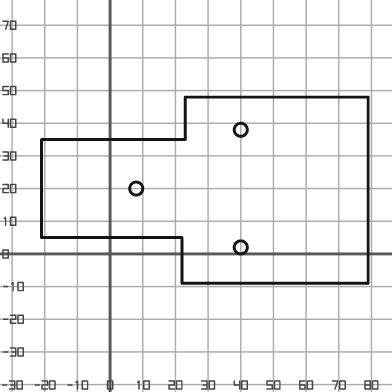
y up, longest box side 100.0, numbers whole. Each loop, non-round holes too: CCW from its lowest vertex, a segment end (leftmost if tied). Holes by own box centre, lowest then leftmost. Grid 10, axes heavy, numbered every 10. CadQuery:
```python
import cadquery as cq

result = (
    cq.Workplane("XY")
    .moveTo(22.0, -9.0)
    .lineTo(79.0, -9.0)
    .lineTo(79.0, 48.0)
    .lineTo(23.0, 48.0)
    .lineTo(23.0, 35.0)
    .lineTo(-21.0, 35.0)
    .lineTo(-21.0, 5.0)
    .lineTo(22.0, 5.0)
    .close()
    .moveTo(40.0, 2.0)
    .circle(2.0)
    .moveTo(8.0, 20.0)
    .circle(2.0)
    .moveTo(40.0, 38.0)
    .circle(2.0)
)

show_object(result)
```